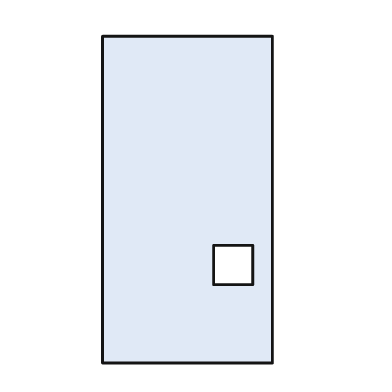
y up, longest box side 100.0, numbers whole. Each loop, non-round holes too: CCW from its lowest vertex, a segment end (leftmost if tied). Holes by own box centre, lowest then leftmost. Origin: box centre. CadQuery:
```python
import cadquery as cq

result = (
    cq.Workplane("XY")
    .moveTo(-26.0, -50.0)
    .lineTo(26.0, -50.0)
    .lineTo(26.0, 50.0)
    .lineTo(-26.0, 50.0)
    .close()
    .moveTo(8.0, -26.0)
    .lineTo(20.0, -26.0)
    .lineTo(20.0, -14.0)
    .lineTo(8.0, -14.0)
    .close()
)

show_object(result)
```